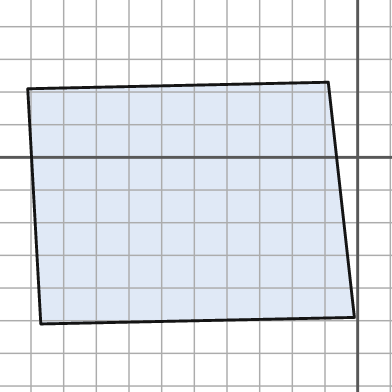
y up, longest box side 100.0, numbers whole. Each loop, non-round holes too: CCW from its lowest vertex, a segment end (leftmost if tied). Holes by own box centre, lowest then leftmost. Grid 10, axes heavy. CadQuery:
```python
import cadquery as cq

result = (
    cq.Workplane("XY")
    .moveTo(-97.0, -51.0)
    .lineTo(-1.0, -49.0)
    .lineTo(-9.0, 23.0)
    .lineTo(-101.0, 21.0)
    .close()
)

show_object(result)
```